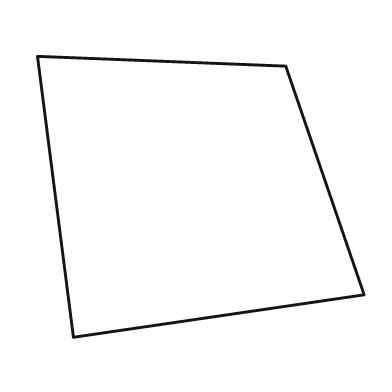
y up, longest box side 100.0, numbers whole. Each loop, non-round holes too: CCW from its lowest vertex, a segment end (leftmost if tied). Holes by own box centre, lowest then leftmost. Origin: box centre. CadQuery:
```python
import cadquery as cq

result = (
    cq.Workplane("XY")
    .moveTo(-39.0, -43.0)
    .lineTo(50.0, -30.0)
    .lineTo(26.0, 40.0)
    .lineTo(-50.0, 43.0)
    .close()
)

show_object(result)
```